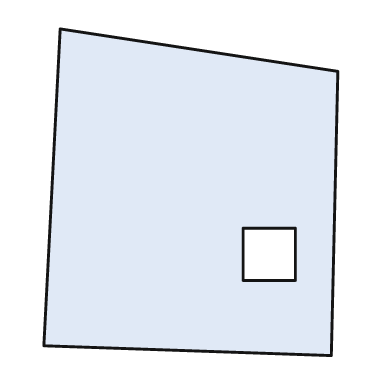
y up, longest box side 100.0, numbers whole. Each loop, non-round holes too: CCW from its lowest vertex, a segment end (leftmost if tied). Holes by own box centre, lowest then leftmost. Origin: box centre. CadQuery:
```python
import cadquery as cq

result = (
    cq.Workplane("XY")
    .moveTo(43.0, -50.0)
    .lineTo(45.0, 37.0)
    .lineTo(-40.0, 50.0)
    .lineTo(-45.0, -47.0)
    .close()
    .moveTo(16.0, -27.0)
    .lineTo(32.0, -27.0)
    .lineTo(32.0, -11.0)
    .lineTo(16.0, -11.0)
    .close()
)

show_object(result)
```